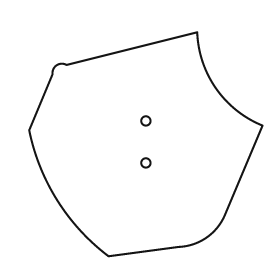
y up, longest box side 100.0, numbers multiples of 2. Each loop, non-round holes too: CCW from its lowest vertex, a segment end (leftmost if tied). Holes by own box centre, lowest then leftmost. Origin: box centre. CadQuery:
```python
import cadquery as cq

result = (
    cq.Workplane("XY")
    .moveTo(-16.0, -48.0)
    .lineTo(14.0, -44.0)
    .threePointArc((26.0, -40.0), (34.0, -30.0))
    .lineTo(50.0, 8.0)
    .threePointArc((30.0, 24.0), (22.0, 48.0))
    .lineTo(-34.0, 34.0)
    .threePointArc((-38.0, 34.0), (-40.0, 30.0))
    .lineTo(-50.0, 6.0)
    .threePointArc((-38.0, -24.0), (-16.0, -48.0))
    .close()
    .moveTo(0.0, -8.0)
    .circle(2.0)
    .moveTo(0.0, 10.0)
    .circle(2.0)
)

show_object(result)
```